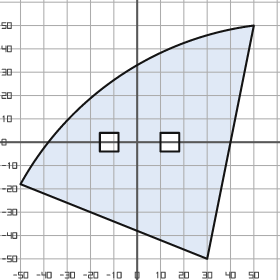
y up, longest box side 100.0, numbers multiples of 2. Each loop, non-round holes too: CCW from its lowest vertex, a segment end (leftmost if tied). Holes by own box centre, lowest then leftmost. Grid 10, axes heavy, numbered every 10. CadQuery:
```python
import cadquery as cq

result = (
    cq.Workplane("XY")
    .moveTo(30.0, -50.0)
    .lineTo(50.0, 50.0)
    .threePointArc((-8.0, 28.0), (-50.0, -18.0))
    .close()
    .moveTo(-16.0, -4.0)
    .lineTo(-8.0, -4.0)
    .lineTo(-8.0, 4.0)
    .lineTo(-16.0, 4.0)
    .close()
    .moveTo(10.0, -4.0)
    .lineTo(18.0, -4.0)
    .lineTo(18.0, 4.0)
    .lineTo(10.0, 4.0)
    .close()
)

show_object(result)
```